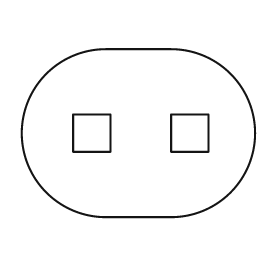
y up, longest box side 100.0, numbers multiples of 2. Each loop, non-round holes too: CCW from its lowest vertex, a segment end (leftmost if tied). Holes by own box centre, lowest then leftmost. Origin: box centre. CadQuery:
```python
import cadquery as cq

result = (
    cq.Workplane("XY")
    .moveTo(-14.0, -36.0)
    .lineTo(14.0, -36.0)
    .threePointArc((50.0, 0.0), (14.0, 36.0))
    .lineTo(-14.0, 36.0)
    .threePointArc((-50.0, 0.0), (-14.0, -36.0))
    .close()
    .moveTo(-28.0, -8.0)
    .lineTo(-12.0, -8.0)
    .lineTo(-12.0, 8.0)
    .lineTo(-28.0, 8.0)
    .close()
    .moveTo(14.0, -8.0)
    .lineTo(30.0, -8.0)
    .lineTo(30.0, 8.0)
    .lineTo(14.0, 8.0)
    .close()
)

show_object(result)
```